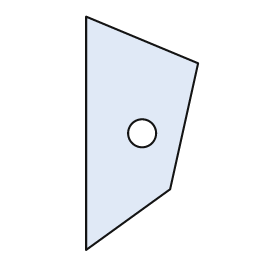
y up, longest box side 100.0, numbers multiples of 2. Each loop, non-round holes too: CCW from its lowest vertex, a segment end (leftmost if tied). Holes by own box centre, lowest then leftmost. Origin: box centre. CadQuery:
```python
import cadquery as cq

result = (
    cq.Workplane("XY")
    .moveTo(-24.0, -50.0)
    .lineTo(12.0, -24.0)
    .lineTo(24.0, 30.0)
    .lineTo(-24.0, 50.0)
    .close()
    .moveTo(0.0, 0.0)
    .circle(6.0)
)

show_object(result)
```